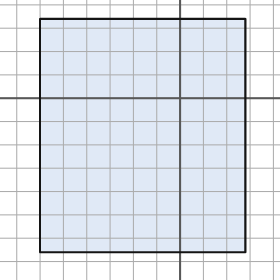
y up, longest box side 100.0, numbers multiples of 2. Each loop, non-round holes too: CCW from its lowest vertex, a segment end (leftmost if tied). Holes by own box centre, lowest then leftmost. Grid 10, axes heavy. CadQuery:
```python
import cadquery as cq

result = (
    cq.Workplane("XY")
    .moveTo(-60.0, -66.0)
    .lineTo(28.0, -66.0)
    .lineTo(28.0, 34.0)
    .lineTo(-60.0, 34.0)
    .close()
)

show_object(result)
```